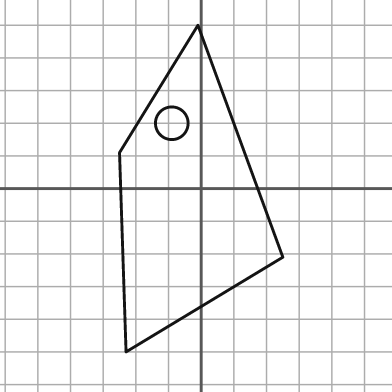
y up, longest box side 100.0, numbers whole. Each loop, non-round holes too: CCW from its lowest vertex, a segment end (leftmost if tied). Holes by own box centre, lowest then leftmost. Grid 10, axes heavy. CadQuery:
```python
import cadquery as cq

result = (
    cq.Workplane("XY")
    .moveTo(-23.0, -50.0)
    .lineTo(25.0, -21.0)
    .lineTo(-1.0, 50.0)
    .lineTo(-25.0, 11.0)
    .close()
    .moveTo(-9.0, 20.0)
    .circle(5.0)
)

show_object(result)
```